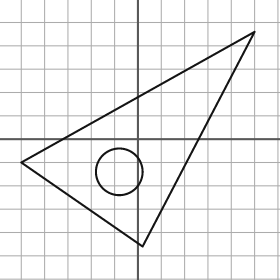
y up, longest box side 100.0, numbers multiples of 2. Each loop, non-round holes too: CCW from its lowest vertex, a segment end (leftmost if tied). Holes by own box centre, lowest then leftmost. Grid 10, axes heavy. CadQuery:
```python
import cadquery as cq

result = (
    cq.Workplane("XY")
    .moveTo(2.0, -46.0)
    .lineTo(50.0, 46.0)
    .lineTo(-50.0, -10.0)
    .close()
    .moveTo(-8.0, -14.0)
    .circle(10.0)
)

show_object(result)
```